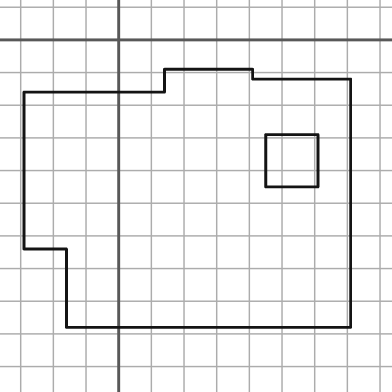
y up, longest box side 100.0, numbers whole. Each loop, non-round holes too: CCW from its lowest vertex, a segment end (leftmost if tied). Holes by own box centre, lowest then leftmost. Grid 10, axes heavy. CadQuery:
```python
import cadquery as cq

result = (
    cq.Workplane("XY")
    .moveTo(-16.0, -88.0)
    .lineTo(71.0, -88.0)
    .lineTo(71.0, -12.0)
    .lineTo(41.0, -12.0)
    .lineTo(41.0, -9.0)
    .lineTo(14.0, -9.0)
    .lineTo(14.0, -16.0)
    .lineTo(-29.0, -16.0)
    .lineTo(-29.0, -64.0)
    .lineTo(-16.0, -64.0)
    .close()
    .moveTo(45.0, -45.0)
    .lineTo(61.0, -45.0)
    .lineTo(61.0, -29.0)
    .lineTo(45.0, -29.0)
    .close()
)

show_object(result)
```